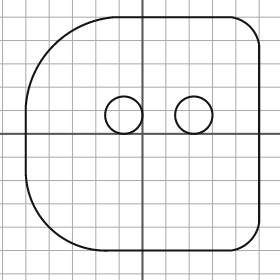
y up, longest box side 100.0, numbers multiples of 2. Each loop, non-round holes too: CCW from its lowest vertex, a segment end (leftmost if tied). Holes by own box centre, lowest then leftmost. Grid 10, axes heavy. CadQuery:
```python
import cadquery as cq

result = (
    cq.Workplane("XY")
    .moveTo(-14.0, -50.0)
    .lineTo(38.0, -50.0)
    .threePointArc((46.0, -46.0), (50.0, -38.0))
    .lineTo(50.0, 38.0)
    .threePointArc((46.0, 46.0), (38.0, 50.0))
    .lineTo(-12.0, 50.0)
    .threePointArc((-38.0, 38.0), (-50.0, 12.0))
    .lineTo(-50.0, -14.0)
    .threePointArc((-40.0, -40.0), (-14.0, -50.0))
    .close()
    .moveTo(-8.0, 8.0)
    .circle(8.0)
    .moveTo(22.0, 8.0)
    .circle(8.0)
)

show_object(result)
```